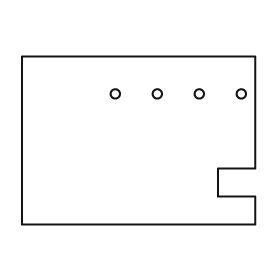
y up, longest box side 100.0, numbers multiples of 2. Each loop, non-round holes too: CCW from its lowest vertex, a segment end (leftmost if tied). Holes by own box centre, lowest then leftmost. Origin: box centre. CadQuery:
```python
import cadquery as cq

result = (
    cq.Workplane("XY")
    .moveTo(-50.0, -36.0)
    .lineTo(50.0, -36.0)
    .lineTo(50.0, -24.0)
    .lineTo(34.0, -24.0)
    .lineTo(34.0, -12.0)
    .lineTo(50.0, -12.0)
    .lineTo(50.0, 36.0)
    .lineTo(-50.0, 36.0)
    .close()
    .moveTo(-10.0, 20.0)
    .circle(2.0)
    .moveTo(8.0, 20.0)
    .circle(2.0)
    .moveTo(26.0, 20.0)
    .circle(2.0)
    .moveTo(44.0, 20.0)
    .circle(2.0)
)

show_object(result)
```